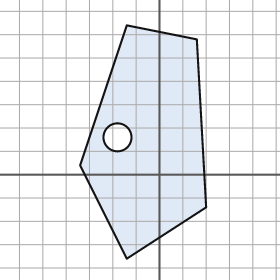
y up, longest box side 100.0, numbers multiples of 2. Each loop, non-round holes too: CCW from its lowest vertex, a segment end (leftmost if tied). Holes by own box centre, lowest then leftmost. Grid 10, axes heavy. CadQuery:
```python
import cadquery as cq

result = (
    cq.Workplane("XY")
    .moveTo(-14.0, -36.0)
    .lineTo(20.0, -14.0)
    .lineTo(16.0, 58.0)
    .lineTo(-14.0, 64.0)
    .lineTo(-34.0, 4.0)
    .close()
    .moveTo(-18.0, 16.0)
    .circle(6.0)
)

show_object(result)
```